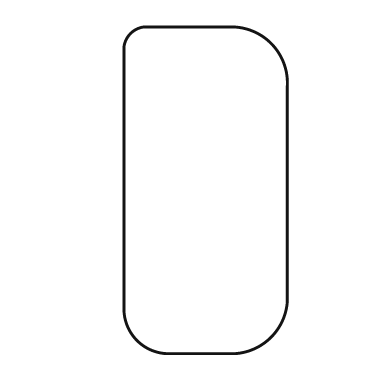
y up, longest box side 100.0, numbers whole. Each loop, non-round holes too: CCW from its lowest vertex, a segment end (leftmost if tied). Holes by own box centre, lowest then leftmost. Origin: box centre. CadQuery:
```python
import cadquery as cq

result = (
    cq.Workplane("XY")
    .moveTo(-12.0, -50.0)
    .lineTo(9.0, -50.0)
    .threePointArc((20.0, -45.0), (25.0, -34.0))
    .lineTo(25.0, 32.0)
    .threePointArc((20.0, 45.0), (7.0, 50.0))
    .lineTo(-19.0, 50.0)
    .threePointArc((-23.0, 48.0), (-25.0, 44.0))
    .lineTo(-25.0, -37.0)
    .threePointArc((-21.0, -46.0), (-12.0, -50.0))
    .close()
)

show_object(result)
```